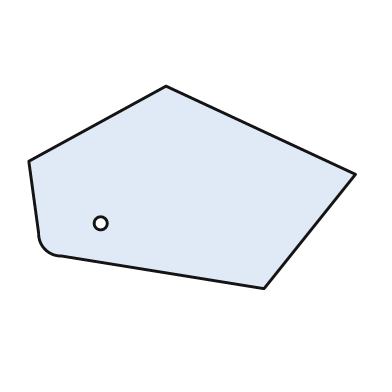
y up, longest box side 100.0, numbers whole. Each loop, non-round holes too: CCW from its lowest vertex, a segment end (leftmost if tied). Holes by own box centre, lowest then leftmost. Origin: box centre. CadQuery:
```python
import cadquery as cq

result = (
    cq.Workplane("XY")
    .moveTo(22.0, -31.0)
    .lineTo(50.0, 4.0)
    .lineTo(-8.0, 31.0)
    .lineTo(-50.0, 8.0)
    .lineTo(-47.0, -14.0)
    .threePointArc((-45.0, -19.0), (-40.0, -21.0))
    .close()
    .moveTo(-28.0, -11.0)
    .circle(2.0)
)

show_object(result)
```